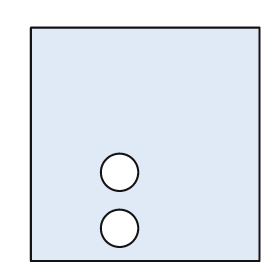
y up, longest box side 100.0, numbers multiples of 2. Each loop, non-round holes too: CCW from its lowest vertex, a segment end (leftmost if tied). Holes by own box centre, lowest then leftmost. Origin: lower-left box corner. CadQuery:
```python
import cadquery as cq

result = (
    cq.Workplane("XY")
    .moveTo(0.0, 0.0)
    .lineTo(98.0, 0.0)
    .lineTo(98.0, 100.0)
    .lineTo(0.0, 100.0)
    .close()
    .moveTo(38.0, 14.0)
    .circle(8.0)
    .moveTo(38.0, 38.0)
    .circle(8.0)
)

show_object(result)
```